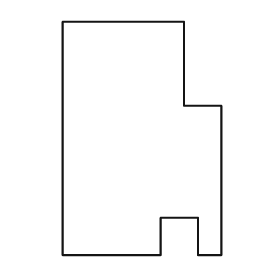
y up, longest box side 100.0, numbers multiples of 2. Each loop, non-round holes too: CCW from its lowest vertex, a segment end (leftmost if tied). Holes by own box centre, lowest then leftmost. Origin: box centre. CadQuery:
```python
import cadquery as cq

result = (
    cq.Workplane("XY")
    .moveTo(-34.0, -50.0)
    .lineTo(8.0, -50.0)
    .lineTo(8.0, -34.0)
    .lineTo(24.0, -34.0)
    .lineTo(24.0, -50.0)
    .lineTo(34.0, -50.0)
    .lineTo(34.0, 14.0)
    .lineTo(18.0, 14.0)
    .lineTo(18.0, 50.0)
    .lineTo(-34.0, 50.0)
    .close()
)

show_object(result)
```